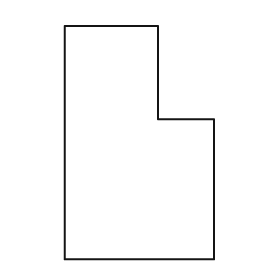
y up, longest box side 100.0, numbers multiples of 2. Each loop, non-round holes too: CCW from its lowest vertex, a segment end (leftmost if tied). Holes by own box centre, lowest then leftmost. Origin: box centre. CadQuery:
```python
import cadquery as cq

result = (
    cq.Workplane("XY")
    .moveTo(-32.0, -50.0)
    .lineTo(32.0, -50.0)
    .lineTo(32.0, 10.0)
    .lineTo(8.0, 10.0)
    .lineTo(8.0, 50.0)
    .lineTo(-32.0, 50.0)
    .close()
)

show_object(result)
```